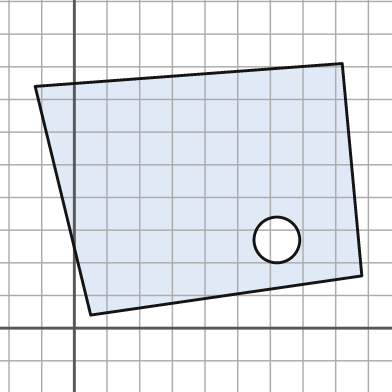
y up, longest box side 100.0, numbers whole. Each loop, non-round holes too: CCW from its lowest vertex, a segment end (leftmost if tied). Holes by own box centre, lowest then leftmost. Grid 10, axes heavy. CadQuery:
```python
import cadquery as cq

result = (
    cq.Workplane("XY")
    .moveTo(5.0, 4.0)
    .lineTo(88.0, 16.0)
    .lineTo(82.0, 81.0)
    .lineTo(-12.0, 74.0)
    .close()
    .moveTo(62.0, 27.0)
    .circle(7.0)
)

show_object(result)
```